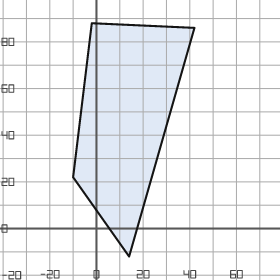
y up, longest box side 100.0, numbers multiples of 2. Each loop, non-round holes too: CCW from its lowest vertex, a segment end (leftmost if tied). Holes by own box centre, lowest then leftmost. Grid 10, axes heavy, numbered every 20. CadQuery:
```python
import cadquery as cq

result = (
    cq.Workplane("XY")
    .moveTo(14.0, -12.0)
    .lineTo(42.0, 86.0)
    .lineTo(-2.0, 88.0)
    .lineTo(-10.0, 22.0)
    .close()
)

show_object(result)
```